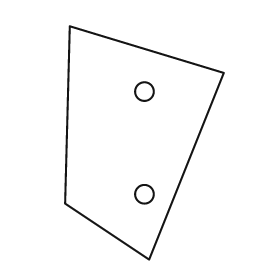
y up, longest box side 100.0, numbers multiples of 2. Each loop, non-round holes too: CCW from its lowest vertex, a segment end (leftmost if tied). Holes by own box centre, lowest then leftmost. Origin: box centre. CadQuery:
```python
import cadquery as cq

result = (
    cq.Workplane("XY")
    .moveTo(2.0, -50.0)
    .lineTo(34.0, 30.0)
    .lineTo(-32.0, 50.0)
    .lineTo(-34.0, -26.0)
    .close()
    .moveTo(0.0, -22.0)
    .circle(4.0)
    .moveTo(0.0, 22.0)
    .circle(4.0)
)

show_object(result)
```